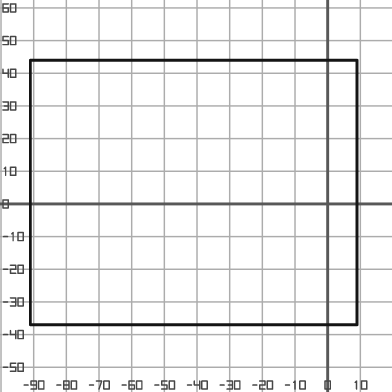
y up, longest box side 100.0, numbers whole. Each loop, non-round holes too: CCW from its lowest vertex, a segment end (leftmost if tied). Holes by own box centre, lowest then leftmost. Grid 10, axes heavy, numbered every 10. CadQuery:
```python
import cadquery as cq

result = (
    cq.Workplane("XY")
    .moveTo(-91.0, -37.0)
    .lineTo(9.0, -37.0)
    .lineTo(9.0, 44.0)
    .lineTo(-91.0, 44.0)
    .close()
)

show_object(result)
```